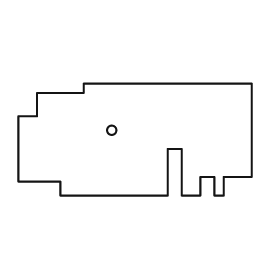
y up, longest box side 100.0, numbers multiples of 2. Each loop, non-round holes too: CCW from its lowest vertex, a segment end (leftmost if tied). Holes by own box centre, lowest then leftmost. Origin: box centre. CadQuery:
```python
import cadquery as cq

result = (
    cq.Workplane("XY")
    .moveTo(-32.0, -24.0)
    .lineTo(14.0, -24.0)
    .lineTo(14.0, -4.0)
    .lineTo(20.0, -4.0)
    .lineTo(20.0, -24.0)
    .lineTo(28.0, -24.0)
    .lineTo(28.0, -16.0)
    .lineTo(34.0, -16.0)
    .lineTo(34.0, -24.0)
    .lineTo(38.0, -24.0)
    .lineTo(38.0, -16.0)
    .lineTo(50.0, -16.0)
    .lineTo(50.0, 24.0)
    .lineTo(-22.0, 24.0)
    .lineTo(-22.0, 20.0)
    .lineTo(-42.0, 20.0)
    .lineTo(-42.0, 10.0)
    .lineTo(-50.0, 10.0)
    .lineTo(-50.0, -18.0)
    .lineTo(-32.0, -18.0)
    .close()
    .moveTo(-10.0, 4.0)
    .circle(2.0)
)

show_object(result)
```